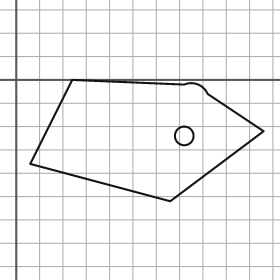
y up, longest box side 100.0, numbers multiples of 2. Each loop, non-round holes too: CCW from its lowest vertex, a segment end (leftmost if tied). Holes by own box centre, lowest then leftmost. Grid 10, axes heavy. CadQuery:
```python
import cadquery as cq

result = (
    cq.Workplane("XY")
    .moveTo(66.0, -52.0)
    .lineTo(106.0, -22.0)
    .lineTo(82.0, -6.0)
    .threePointArc((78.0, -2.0), (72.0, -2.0))
    .lineTo(24.0, 0.0)
    .lineTo(6.0, -36.0)
    .close()
    .moveTo(72.0, -24.0)
    .circle(4.0)
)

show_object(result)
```